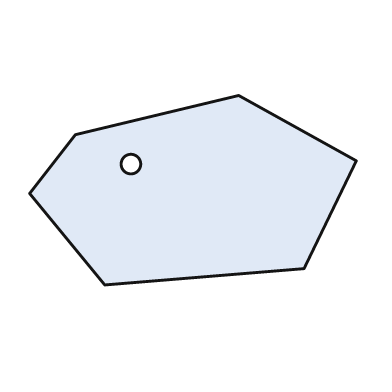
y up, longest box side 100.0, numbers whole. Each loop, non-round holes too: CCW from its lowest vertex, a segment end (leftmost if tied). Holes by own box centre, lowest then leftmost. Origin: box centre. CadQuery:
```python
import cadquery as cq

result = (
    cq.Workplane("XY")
    .moveTo(-27.0, -29.0)
    .lineTo(34.0, -24.0)
    .lineTo(50.0, 9.0)
    .lineTo(14.0, 29.0)
    .lineTo(-36.0, 17.0)
    .lineTo(-50.0, -1.0)
    .close()
    .moveTo(-19.0, 8.0)
    .circle(3.0)
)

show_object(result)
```